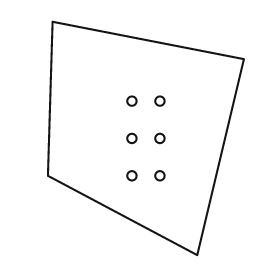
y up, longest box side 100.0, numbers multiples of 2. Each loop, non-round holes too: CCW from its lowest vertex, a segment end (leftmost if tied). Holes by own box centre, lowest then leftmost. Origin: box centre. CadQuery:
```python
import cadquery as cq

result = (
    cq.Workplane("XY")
    .moveTo(22.0, -50.0)
    .lineTo(42.0, 34.0)
    .lineTo(-40.0, 50.0)
    .lineTo(-42.0, -16.0)
    .close()
    .moveTo(-6.0, -16.0)
    .circle(2.0)
    .moveTo(6.0, -16.0)
    .circle(2.0)
    .moveTo(-6.0, 0.0)
    .circle(2.0)
    .moveTo(6.0, 0.0)
    .circle(2.0)
    .moveTo(-6.0, 16.0)
    .circle(2.0)
    .moveTo(6.0, 16.0)
    .circle(2.0)
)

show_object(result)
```